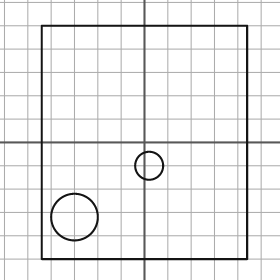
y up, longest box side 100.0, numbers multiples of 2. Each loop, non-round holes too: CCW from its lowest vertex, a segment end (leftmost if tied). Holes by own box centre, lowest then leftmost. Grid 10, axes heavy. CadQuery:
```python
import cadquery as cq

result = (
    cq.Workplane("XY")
    .moveTo(-44.0, -50.0)
    .lineTo(44.0, -50.0)
    .lineTo(44.0, 50.0)
    .lineTo(-44.0, 50.0)
    .close()
    .moveTo(-30.0, -32.0)
    .circle(10.0)
    .moveTo(2.0, -10.0)
    .circle(6.0)
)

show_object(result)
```